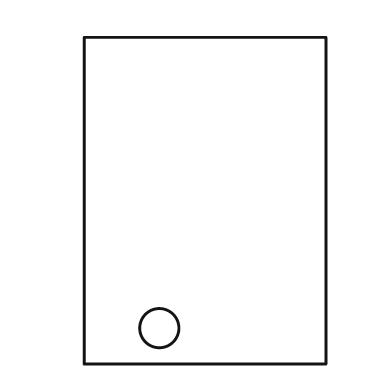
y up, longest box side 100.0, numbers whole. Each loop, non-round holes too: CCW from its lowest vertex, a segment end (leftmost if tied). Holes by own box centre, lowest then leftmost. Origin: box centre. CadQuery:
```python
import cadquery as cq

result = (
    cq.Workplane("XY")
    .moveTo(-37.0, -50.0)
    .lineTo(37.0, -50.0)
    .lineTo(37.0, 50.0)
    .lineTo(-37.0, 50.0)
    .close()
    .moveTo(-14.0, -39.0)
    .circle(6.0)
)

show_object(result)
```